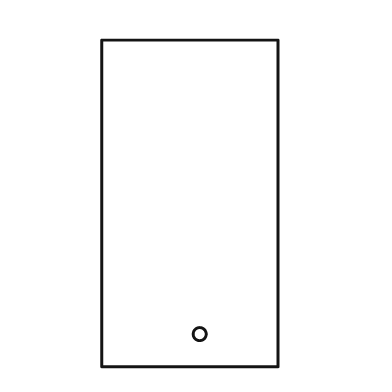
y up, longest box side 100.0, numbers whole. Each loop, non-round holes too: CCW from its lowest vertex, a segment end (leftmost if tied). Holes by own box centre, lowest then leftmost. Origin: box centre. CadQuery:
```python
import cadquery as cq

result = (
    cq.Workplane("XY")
    .moveTo(-27.0, -50.0)
    .lineTo(27.0, -50.0)
    .lineTo(27.0, 50.0)
    .lineTo(-27.0, 50.0)
    .close()
    .moveTo(3.0, -40.0)
    .circle(2.0)
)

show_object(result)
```